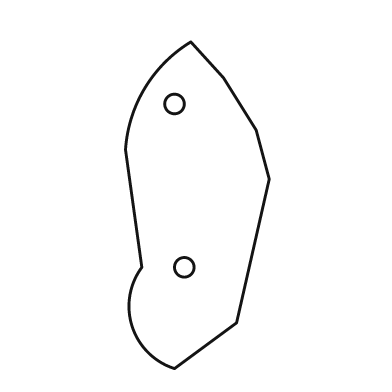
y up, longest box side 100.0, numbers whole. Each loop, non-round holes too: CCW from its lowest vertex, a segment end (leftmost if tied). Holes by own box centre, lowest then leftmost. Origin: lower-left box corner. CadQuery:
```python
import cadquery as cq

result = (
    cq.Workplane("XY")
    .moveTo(15.0, 0.0)
    .lineTo(34.0, 14.0)
    .lineTo(44.0, 58.0)
    .lineTo(40.0, 73.0)
    .lineTo(30.0, 89.0)
    .lineTo(20.0, 100.0)
    .threePointArc((6.0, 86.0), (0.0, 67.0))
    .lineTo(5.0, 31.0)
    .threePointArc((2.0, 13.0), (15.0, 0.0))
    .close()
    .moveTo(18.0, 31.0)
    .circle(3.0)
    .moveTo(15.0, 81.0)
    .circle(3.0)
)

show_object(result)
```